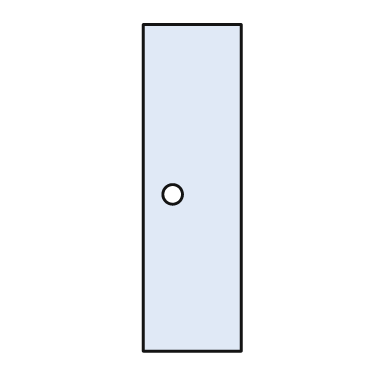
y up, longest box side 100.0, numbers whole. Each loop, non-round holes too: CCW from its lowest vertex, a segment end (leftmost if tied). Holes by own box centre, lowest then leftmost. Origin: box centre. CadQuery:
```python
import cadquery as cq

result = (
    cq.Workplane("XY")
    .moveTo(-15.0, -50.0)
    .lineTo(15.0, -50.0)
    .lineTo(15.0, 50.0)
    .lineTo(-15.0, 50.0)
    .close()
    .moveTo(-6.0, -2.0)
    .circle(3.0)
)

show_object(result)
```